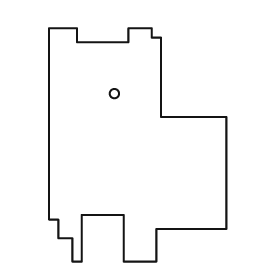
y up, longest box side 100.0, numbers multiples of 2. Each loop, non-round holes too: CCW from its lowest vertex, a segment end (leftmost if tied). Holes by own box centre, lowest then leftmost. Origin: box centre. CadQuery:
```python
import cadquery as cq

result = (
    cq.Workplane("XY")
    .moveTo(-28.0, -50.0)
    .lineTo(-24.0, -50.0)
    .lineTo(-24.0, -30.0)
    .lineTo(-6.0, -30.0)
    .lineTo(-6.0, -50.0)
    .lineTo(8.0, -50.0)
    .lineTo(8.0, -36.0)
    .lineTo(38.0, -36.0)
    .lineTo(38.0, 12.0)
    .lineTo(10.0, 12.0)
    .lineTo(10.0, 46.0)
    .lineTo(6.0, 46.0)
    .lineTo(6.0, 50.0)
    .lineTo(-4.0, 50.0)
    .lineTo(-4.0, 44.0)
    .lineTo(-26.0, 44.0)
    .lineTo(-26.0, 50.0)
    .lineTo(-38.0, 50.0)
    .lineTo(-38.0, -32.0)
    .lineTo(-34.0, -32.0)
    .lineTo(-34.0, -40.0)
    .lineTo(-28.0, -40.0)
    .close()
    .moveTo(-10.0, 22.0)
    .circle(2.0)
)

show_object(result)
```